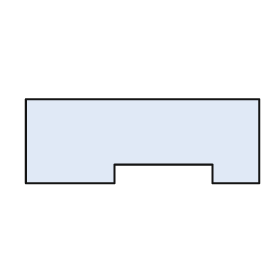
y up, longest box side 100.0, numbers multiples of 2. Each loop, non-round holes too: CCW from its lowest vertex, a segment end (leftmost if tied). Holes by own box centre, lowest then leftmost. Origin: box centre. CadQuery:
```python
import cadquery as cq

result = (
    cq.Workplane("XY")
    .moveTo(-50.0, -18.0)
    .lineTo(-12.0, -18.0)
    .lineTo(-12.0, -10.0)
    .lineTo(30.0, -10.0)
    .lineTo(30.0, -18.0)
    .lineTo(50.0, -18.0)
    .lineTo(50.0, 18.0)
    .lineTo(-50.0, 18.0)
    .close()
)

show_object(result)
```